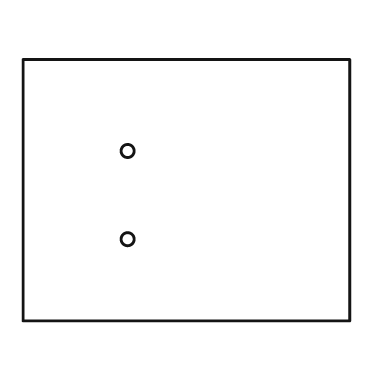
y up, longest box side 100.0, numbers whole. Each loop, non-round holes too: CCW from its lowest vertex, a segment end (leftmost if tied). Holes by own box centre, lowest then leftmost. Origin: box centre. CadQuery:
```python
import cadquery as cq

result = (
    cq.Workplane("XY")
    .moveTo(-50.0, -40.0)
    .lineTo(50.0, -40.0)
    .lineTo(50.0, 40.0)
    .lineTo(-50.0, 40.0)
    .close()
    .moveTo(-18.0, -15.0)
    .circle(2.0)
    .moveTo(-18.0, 12.0)
    .circle(2.0)
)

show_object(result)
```